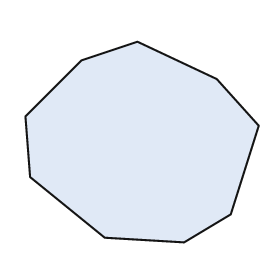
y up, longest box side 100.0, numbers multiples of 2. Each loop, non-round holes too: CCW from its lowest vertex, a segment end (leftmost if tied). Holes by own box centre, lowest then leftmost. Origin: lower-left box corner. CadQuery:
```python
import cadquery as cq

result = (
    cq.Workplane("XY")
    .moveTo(68.0, 0.0)
    .lineTo(88.0, 12.0)
    .lineTo(100.0, 50.0)
    .lineTo(82.0, 70.0)
    .lineTo(48.0, 86.0)
    .lineTo(24.0, 78.0)
    .lineTo(0.0, 54.0)
    .lineTo(2.0, 28.0)
    .lineTo(34.0, 2.0)
    .close()
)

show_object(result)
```